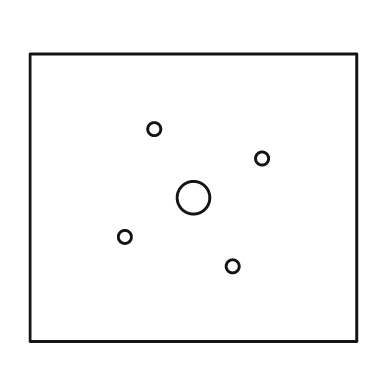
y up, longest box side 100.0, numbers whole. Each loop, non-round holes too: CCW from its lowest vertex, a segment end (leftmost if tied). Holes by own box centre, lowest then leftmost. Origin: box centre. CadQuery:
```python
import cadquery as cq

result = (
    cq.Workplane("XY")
    .moveTo(-50.0, -44.0)
    .lineTo(50.0, -44.0)
    .lineTo(50.0, 44.0)
    .lineTo(-50.0, 44.0)
    .close()
    .moveTo(12.0, -21.0)
    .circle(2.0)
    .moveTo(-21.0, -12.0)
    .circle(2.0)
    .moveTo(0.0, 0.0)
    .circle(5.0)
    .moveTo(21.0, 12.0)
    .circle(2.0)
    .moveTo(-12.0, 21.0)
    .circle(2.0)
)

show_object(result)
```